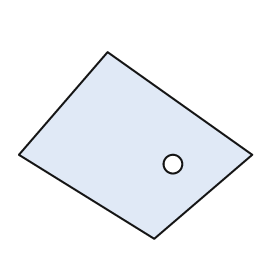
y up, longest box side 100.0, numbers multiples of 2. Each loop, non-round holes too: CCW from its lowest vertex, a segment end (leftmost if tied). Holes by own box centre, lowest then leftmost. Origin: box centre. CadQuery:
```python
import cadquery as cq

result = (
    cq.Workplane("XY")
    .moveTo(8.0, -40.0)
    .lineTo(50.0, -4.0)
    .lineTo(-12.0, 40.0)
    .lineTo(-50.0, -4.0)
    .close()
    .moveTo(16.0, -8.0)
    .circle(4.0)
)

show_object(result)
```